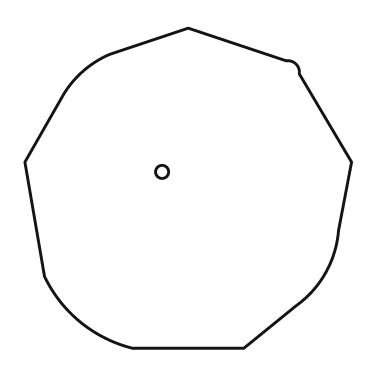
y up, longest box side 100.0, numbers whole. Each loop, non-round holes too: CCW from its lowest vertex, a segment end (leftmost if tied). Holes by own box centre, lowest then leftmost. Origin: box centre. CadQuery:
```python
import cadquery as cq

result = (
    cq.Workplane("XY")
    .moveTo(-17.0, -49.0)
    .lineTo(17.0, -49.0)
    .lineTo(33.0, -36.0)
    .threePointArc((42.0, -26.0), (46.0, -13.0))
    .lineTo(50.0, 8.0)
    .lineTo(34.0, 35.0)
    .threePointArc((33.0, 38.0), (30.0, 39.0))
    .lineTo(0.0, 49.0)
    .lineTo(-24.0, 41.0)
    .threePointArc((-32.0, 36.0), (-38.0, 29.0))
    .lineTo(-50.0, 8.0)
    .lineTo(-44.0, -27.0)
    .threePointArc((-33.0, -41.0), (-17.0, -49.0))
    .close()
    .moveTo(-8.0, 5.0)
    .circle(2.0)
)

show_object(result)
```